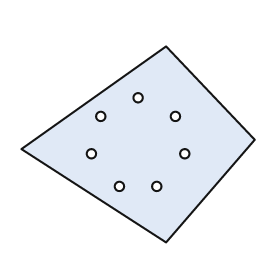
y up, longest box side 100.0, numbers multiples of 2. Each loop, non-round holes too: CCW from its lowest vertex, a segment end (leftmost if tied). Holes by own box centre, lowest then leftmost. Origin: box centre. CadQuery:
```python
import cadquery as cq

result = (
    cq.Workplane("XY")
    .moveTo(12.0, -42.0)
    .lineTo(50.0, 2.0)
    .lineTo(12.0, 42.0)
    .lineTo(-50.0, -2.0)
    .close()
    .moveTo(-8.0, -18.0)
    .circle(2.0)
    .moveTo(8.0, -18.0)
    .circle(2.0)
    .moveTo(-20.0, -4.0)
    .circle(2.0)
    .moveTo(20.0, -4.0)
    .circle(2.0)
    .moveTo(-16.0, 12.0)
    .circle(2.0)
    .moveTo(16.0, 12.0)
    .circle(2.0)
    .moveTo(0.0, 20.0)
    .circle(2.0)
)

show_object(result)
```